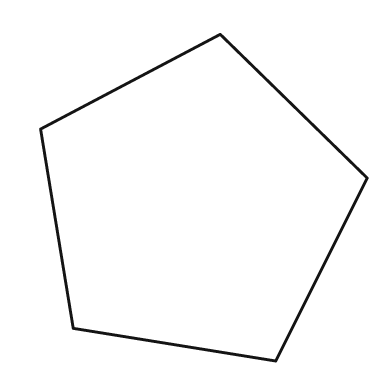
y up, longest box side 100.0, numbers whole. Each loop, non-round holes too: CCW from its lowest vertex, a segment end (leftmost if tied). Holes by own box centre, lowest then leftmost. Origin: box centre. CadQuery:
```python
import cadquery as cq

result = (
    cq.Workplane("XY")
    .moveTo(22.0, -50.0)
    .lineTo(50.0, 6.0)
    .lineTo(5.0, 50.0)
    .lineTo(-50.0, 21.0)
    .lineTo(-40.0, -40.0)
    .close()
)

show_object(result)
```